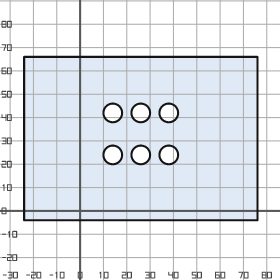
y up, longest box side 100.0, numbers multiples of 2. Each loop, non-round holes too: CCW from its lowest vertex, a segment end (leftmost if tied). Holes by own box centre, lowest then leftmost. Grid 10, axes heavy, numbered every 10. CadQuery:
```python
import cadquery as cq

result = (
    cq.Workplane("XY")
    .moveTo(-24.0, -4.0)
    .lineTo(76.0, -4.0)
    .lineTo(76.0, 66.0)
    .lineTo(-24.0, 66.0)
    .close()
    .moveTo(14.0, 24.0)
    .circle(4.0)
    .moveTo(26.0, 24.0)
    .circle(4.0)
    .moveTo(38.0, 24.0)
    .circle(4.0)
    .moveTo(14.0, 42.0)
    .circle(4.0)
    .moveTo(26.0, 42.0)
    .circle(4.0)
    .moveTo(38.0, 42.0)
    .circle(4.0)
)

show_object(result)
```